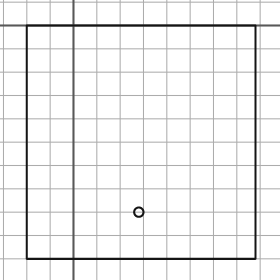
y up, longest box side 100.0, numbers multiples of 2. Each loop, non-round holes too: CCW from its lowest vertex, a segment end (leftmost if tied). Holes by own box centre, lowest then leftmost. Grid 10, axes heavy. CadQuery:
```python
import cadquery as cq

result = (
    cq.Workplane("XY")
    .moveTo(-20.0, -100.0)
    .lineTo(78.0, -100.0)
    .lineTo(78.0, 0.0)
    .lineTo(-20.0, 0.0)
    .close()
    .moveTo(28.0, -80.0)
    .circle(2.0)
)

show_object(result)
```